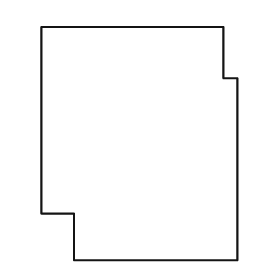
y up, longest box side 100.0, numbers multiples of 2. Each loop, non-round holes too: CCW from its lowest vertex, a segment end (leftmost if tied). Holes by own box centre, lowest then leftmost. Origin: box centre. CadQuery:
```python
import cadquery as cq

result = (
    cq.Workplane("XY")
    .moveTo(-28.0, -50.0)
    .lineTo(42.0, -50.0)
    .lineTo(42.0, 28.0)
    .lineTo(36.0, 28.0)
    .lineTo(36.0, 50.0)
    .lineTo(-42.0, 50.0)
    .lineTo(-42.0, -30.0)
    .lineTo(-28.0, -30.0)
    .close()
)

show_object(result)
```